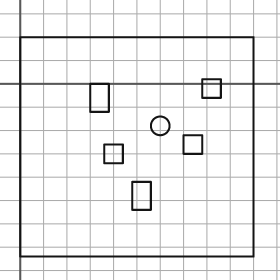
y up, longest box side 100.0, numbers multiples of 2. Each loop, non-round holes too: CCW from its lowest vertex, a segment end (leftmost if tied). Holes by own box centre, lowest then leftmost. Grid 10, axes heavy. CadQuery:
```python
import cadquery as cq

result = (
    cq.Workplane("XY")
    .moveTo(0.0, -74.0)
    .lineTo(100.0, -74.0)
    .lineTo(100.0, 20.0)
    .lineTo(0.0, 20.0)
    .close()
    .moveTo(48.0, -54.0)
    .lineTo(56.0, -54.0)
    .lineTo(56.0, -42.0)
    .lineTo(48.0, -42.0)
    .close()
    .moveTo(36.0, -34.0)
    .lineTo(44.0, -34.0)
    .lineTo(44.0, -26.0)
    .lineTo(36.0, -26.0)
    .close()
    .moveTo(70.0, -30.0)
    .lineTo(78.0, -30.0)
    .lineTo(78.0, -22.0)
    .lineTo(70.0, -22.0)
    .close()
    .moveTo(60.0, -18.0)
    .circle(4.0)
    .moveTo(30.0, -12.0)
    .lineTo(38.0, -12.0)
    .lineTo(38.0, 0.0)
    .lineTo(30.0, 0.0)
    .close()
    .moveTo(78.0, -6.0)
    .lineTo(86.0, -6.0)
    .lineTo(86.0, 2.0)
    .lineTo(78.0, 2.0)
    .close()
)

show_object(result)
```